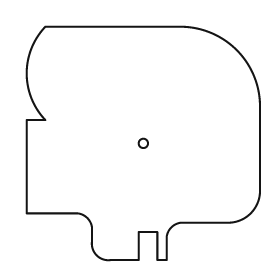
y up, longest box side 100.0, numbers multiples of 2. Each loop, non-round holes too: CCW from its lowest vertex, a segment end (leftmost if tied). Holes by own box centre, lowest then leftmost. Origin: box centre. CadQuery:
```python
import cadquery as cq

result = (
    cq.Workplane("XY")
    .moveTo(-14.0, -50.0)
    .lineTo(-2.0, -50.0)
    .lineTo(-2.0, -38.0)
    .lineTo(6.0, -38.0)
    .lineTo(6.0, -50.0)
    .lineTo(10.0, -50.0)
    .lineTo(10.0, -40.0)
    .threePointArc((12.0, -36.0), (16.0, -34.0))
    .lineTo(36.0, -34.0)
    .threePointArc((46.0, -30.0), (50.0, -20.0))
    .lineTo(50.0, 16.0)
    .threePointArc((40.0, 40.0), (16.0, 50.0))
    .lineTo(-42.0, 50.0)
    .threePointArc((-50.0, 30.0), (-42.0, 10.0))
    .lineTo(-50.0, 10.0)
    .lineTo(-50.0, -30.0)
    .lineTo(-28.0, -30.0)
    .threePointArc((-24.0, -32.0), (-22.0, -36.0))
    .lineTo(-22.0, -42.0)
    .threePointArc((-20.0, -48.0), (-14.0, -50.0))
    .close()
    .moveTo(0.0, 0.0)
    .circle(2.0)
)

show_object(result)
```